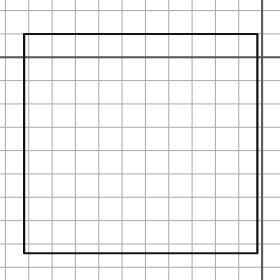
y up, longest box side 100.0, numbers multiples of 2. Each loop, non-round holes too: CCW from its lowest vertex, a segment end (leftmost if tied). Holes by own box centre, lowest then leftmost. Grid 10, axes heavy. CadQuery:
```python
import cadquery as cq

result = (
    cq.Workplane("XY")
    .moveTo(-102.0, -84.0)
    .lineTo(-2.0, -84.0)
    .lineTo(-2.0, 10.0)
    .lineTo(-102.0, 10.0)
    .close()
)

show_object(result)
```